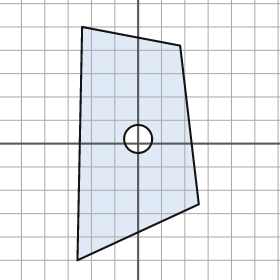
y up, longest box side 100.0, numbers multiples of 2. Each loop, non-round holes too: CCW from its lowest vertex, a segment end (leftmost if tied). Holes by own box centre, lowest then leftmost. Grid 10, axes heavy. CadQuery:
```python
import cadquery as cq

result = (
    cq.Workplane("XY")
    .moveTo(-26.0, -50.0)
    .lineTo(26.0, -26.0)
    .lineTo(18.0, 42.0)
    .lineTo(-24.0, 50.0)
    .close()
    .moveTo(0.0, 2.0)
    .circle(6.0)
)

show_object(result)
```